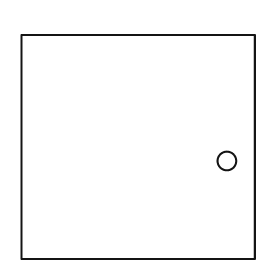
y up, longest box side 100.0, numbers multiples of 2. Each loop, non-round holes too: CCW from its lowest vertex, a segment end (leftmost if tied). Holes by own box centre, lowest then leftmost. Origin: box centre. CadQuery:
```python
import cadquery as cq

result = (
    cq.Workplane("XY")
    .moveTo(-50.0, -48.0)
    .lineTo(50.0, -48.0)
    .lineTo(50.0, 48.0)
    .lineTo(-50.0, 48.0)
    .close()
    .moveTo(38.0, -6.0)
    .circle(4.0)
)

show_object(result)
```